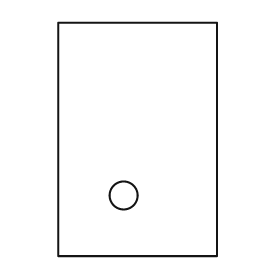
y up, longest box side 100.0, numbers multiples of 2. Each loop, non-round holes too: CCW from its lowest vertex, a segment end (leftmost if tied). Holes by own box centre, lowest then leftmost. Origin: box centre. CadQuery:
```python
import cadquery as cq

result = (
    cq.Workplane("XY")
    .moveTo(-34.0, -50.0)
    .lineTo(34.0, -50.0)
    .lineTo(34.0, 50.0)
    .lineTo(-34.0, 50.0)
    .close()
    .moveTo(-6.0, -24.0)
    .circle(6.0)
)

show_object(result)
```